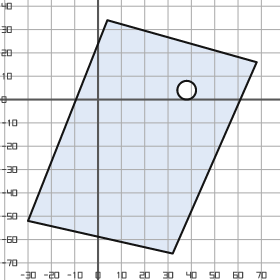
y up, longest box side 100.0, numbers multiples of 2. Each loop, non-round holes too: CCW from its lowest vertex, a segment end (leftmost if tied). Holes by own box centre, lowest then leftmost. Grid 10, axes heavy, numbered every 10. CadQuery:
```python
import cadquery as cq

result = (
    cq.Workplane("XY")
    .moveTo(32.0, -66.0)
    .lineTo(68.0, 16.0)
    .lineTo(4.0, 34.0)
    .lineTo(-30.0, -52.0)
    .close()
    .moveTo(38.0, 4.0)
    .circle(4.0)
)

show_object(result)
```